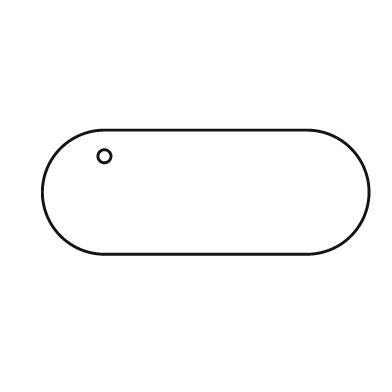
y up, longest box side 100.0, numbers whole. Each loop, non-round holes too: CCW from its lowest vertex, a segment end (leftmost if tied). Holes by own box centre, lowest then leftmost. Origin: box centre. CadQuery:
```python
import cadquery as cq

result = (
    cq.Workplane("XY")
    .moveTo(-31.0, -19.0)
    .lineTo(31.0, -19.0)
    .threePointArc((50.0, 0.0), (31.0, 19.0))
    .lineTo(-31.0, 19.0)
    .threePointArc((-50.0, 0.0), (-31.0, -19.0))
    .close()
    .moveTo(-31.0, 11.0)
    .circle(2.0)
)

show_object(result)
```